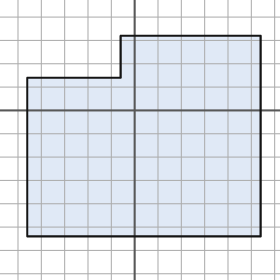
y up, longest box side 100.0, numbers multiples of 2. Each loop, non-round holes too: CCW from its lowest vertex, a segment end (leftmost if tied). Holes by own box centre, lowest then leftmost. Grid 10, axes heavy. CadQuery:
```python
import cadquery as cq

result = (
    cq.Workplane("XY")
    .moveTo(-46.0, -54.0)
    .lineTo(54.0, -54.0)
    .lineTo(54.0, 32.0)
    .lineTo(-6.0, 32.0)
    .lineTo(-6.0, 14.0)
    .lineTo(-46.0, 14.0)
    .close()
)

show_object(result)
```